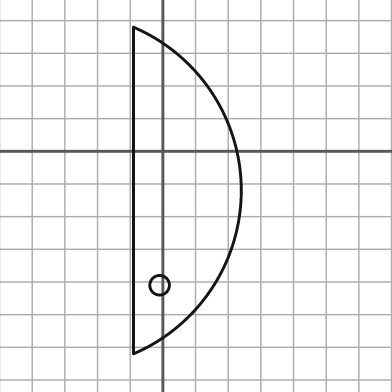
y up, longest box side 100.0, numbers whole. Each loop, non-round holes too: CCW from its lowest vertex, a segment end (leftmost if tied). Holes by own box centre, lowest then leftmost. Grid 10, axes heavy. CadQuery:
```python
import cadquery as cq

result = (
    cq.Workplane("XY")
    .moveTo(-9.0, -62.0)
    .threePointArc((24.0, -12.0), (-9.0, 38.0))
    .close()
    .moveTo(-1.0, -41.0)
    .circle(3.0)
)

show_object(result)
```